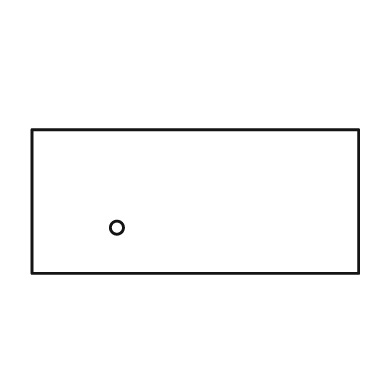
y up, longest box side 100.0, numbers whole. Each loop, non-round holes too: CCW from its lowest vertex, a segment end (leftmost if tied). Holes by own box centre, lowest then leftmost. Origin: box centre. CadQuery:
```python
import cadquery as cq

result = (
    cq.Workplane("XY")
    .moveTo(-50.0, -22.0)
    .lineTo(50.0, -22.0)
    .lineTo(50.0, 22.0)
    .lineTo(-50.0, 22.0)
    .close()
    .moveTo(-24.0, -8.0)
    .circle(2.0)
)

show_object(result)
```